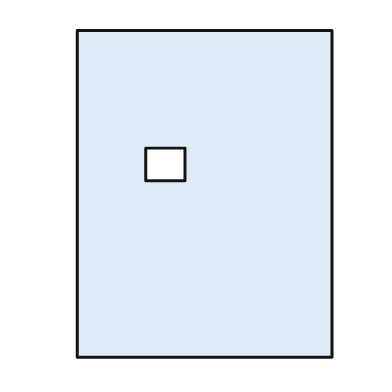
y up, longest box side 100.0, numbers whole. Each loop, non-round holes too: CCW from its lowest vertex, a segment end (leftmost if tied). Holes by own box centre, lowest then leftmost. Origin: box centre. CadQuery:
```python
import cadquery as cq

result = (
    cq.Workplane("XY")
    .moveTo(-39.0, -50.0)
    .lineTo(39.0, -50.0)
    .lineTo(39.0, 50.0)
    .lineTo(-39.0, 50.0)
    .close()
    .moveTo(-18.0, 4.0)
    .lineTo(-6.0, 4.0)
    .lineTo(-6.0, 14.0)
    .lineTo(-18.0, 14.0)
    .close()
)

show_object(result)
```